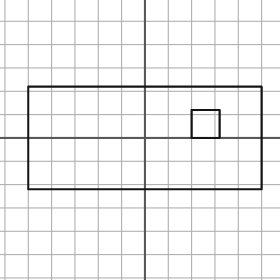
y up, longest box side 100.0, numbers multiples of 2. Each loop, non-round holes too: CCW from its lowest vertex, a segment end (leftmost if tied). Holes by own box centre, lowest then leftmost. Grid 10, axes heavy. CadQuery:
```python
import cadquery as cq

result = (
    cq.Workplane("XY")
    .moveTo(-50.0, -22.0)
    .lineTo(50.0, -22.0)
    .lineTo(50.0, 22.0)
    .lineTo(-50.0, 22.0)
    .close()
    .moveTo(20.0, 0.0)
    .lineTo(32.0, 0.0)
    .lineTo(32.0, 12.0)
    .lineTo(20.0, 12.0)
    .close()
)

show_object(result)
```